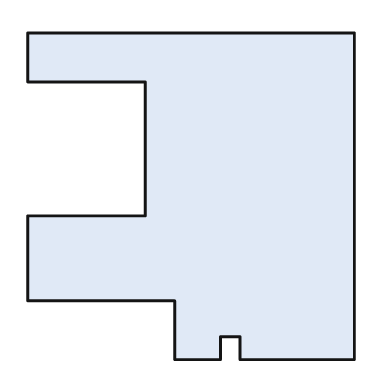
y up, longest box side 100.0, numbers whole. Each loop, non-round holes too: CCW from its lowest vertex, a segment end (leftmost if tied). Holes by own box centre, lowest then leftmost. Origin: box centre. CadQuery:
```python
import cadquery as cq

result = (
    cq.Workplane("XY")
    .moveTo(-5.0, -50.0)
    .lineTo(9.0, -50.0)
    .lineTo(9.0, -43.0)
    .lineTo(15.0, -43.0)
    .lineTo(15.0, -50.0)
    .lineTo(50.0, -50.0)
    .lineTo(50.0, 50.0)
    .lineTo(-50.0, 50.0)
    .lineTo(-50.0, 35.0)
    .lineTo(-14.0, 35.0)
    .lineTo(-14.0, -6.0)
    .lineTo(-50.0, -6.0)
    .lineTo(-50.0, -32.0)
    .lineTo(-5.0, -32.0)
    .close()
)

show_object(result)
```